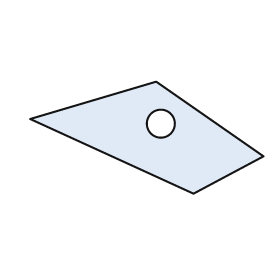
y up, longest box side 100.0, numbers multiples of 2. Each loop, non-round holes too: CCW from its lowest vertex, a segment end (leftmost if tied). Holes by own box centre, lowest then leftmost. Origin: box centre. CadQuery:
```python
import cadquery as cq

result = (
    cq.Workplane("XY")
    .moveTo(20.0, -24.0)
    .lineTo(50.0, -8.0)
    .lineTo(4.0, 24.0)
    .lineTo(-50.0, 8.0)
    .close()
    .moveTo(6.0, 6.0)
    .circle(6.0)
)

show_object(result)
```